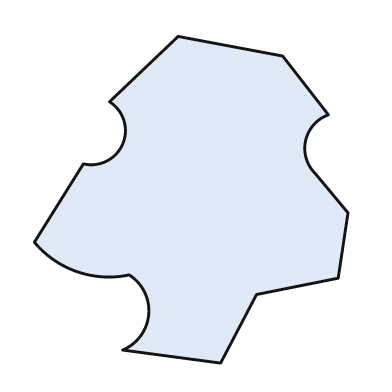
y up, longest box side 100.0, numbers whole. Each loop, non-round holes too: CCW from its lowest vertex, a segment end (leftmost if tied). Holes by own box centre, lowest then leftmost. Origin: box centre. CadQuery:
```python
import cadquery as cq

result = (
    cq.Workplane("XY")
    .moveTo(9.0, -50.0)
    .lineTo(20.0, -29.0)
    .lineTo(45.0, -24.0)
    .lineTo(48.0, -4.0)
    .lineTo(38.0, 8.0)
    .threePointArc((35.0, 18.0), (42.0, 26.0))
    .lineTo(28.0, 44.0)
    .lineTo(-4.0, 50.0)
    .lineTo(-25.0, 30.0)
    .threePointArc((-21.0, 17.0), (-33.0, 11.0))
    .lineTo(-48.0, -13.0)
    .threePointArc((-35.0, -22.0), (-19.0, -23.0))
    .threePointArc((-13.0, -35.0), (-21.0, -46.0))
    .close()
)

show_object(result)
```